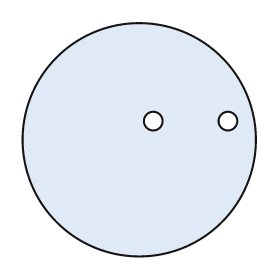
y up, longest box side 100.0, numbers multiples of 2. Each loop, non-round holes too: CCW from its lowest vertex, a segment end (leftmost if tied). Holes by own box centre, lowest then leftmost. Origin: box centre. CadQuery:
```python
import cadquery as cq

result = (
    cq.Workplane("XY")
    .moveTo(0.0, 0.0)
    .circle(50.0)
    .moveTo(6.0, 8.0)
    .circle(4.0)
    .moveTo(38.0, 8.0)
    .circle(4.0)
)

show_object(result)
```